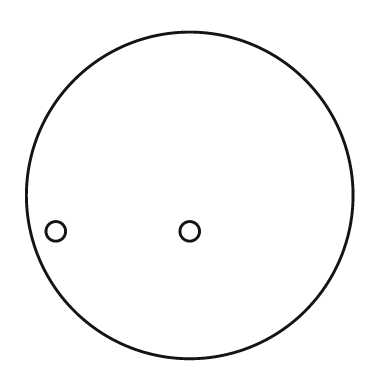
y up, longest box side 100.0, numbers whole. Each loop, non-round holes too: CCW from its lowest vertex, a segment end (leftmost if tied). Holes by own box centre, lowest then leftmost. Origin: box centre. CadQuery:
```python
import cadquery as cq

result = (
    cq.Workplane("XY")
    .moveTo(0.0, 0.0)
    .circle(50.0)
    .moveTo(-41.0, -11.0)
    .circle(3.0)
    .moveTo(0.0, -11.0)
    .circle(3.0)
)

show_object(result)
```